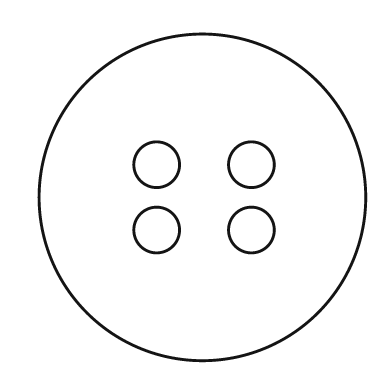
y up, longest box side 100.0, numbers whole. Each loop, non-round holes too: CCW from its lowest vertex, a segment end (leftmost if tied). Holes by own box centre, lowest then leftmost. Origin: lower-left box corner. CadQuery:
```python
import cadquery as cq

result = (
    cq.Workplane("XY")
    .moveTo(50.0, 50.0)
    .circle(50.0)
    .moveTo(36.0, 40.0)
    .circle(7.0)
    .moveTo(65.0, 40.0)
    .circle(7.0)
    .moveTo(36.0, 60.0)
    .circle(7.0)
    .moveTo(65.0, 60.0)
    .circle(7.0)
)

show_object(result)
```